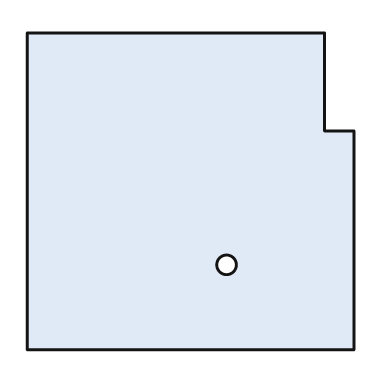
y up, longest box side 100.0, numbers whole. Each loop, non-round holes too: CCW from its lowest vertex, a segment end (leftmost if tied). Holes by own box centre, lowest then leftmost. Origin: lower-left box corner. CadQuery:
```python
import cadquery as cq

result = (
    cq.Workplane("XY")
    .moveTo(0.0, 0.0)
    .lineTo(100.0, 0.0)
    .lineTo(100.0, 67.0)
    .lineTo(91.0, 67.0)
    .lineTo(91.0, 97.0)
    .lineTo(0.0, 97.0)
    .close()
    .moveTo(61.0, 26.0)
    .circle(3.0)
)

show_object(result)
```